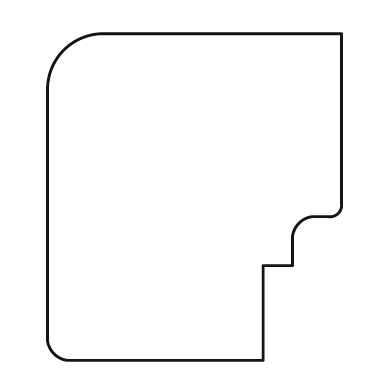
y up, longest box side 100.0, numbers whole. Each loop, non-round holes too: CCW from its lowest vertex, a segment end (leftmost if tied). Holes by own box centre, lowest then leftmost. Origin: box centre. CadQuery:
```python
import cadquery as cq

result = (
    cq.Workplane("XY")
    .moveTo(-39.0, -50.0)
    .lineTo(21.0, -50.0)
    .lineTo(21.0, -21.0)
    .lineTo(30.0, -21.0)
    .lineTo(30.0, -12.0)
    .threePointArc((32.0, -8.0), (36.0, -6.0))
    .lineTo(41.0, -6.0)
    .threePointArc((44.0, -5.0), (45.0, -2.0))
    .lineTo(45.0, 50.0)
    .lineTo(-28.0, 50.0)
    .threePointArc((-40.0, 45.0), (-45.0, 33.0))
    .lineTo(-45.0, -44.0)
    .threePointArc((-43.0, -48.0), (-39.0, -50.0))
    .close()
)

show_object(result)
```